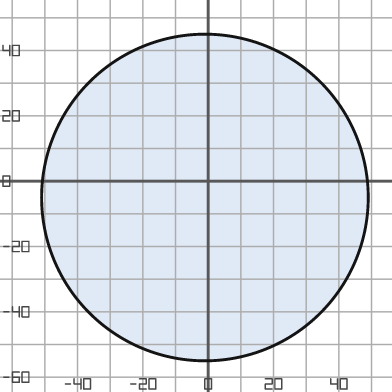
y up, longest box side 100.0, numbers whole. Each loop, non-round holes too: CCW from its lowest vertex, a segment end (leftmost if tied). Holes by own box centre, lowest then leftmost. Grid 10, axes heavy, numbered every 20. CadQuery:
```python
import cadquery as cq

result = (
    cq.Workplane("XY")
    .moveTo(-1.0, -5.0)
    .circle(50.0)
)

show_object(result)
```